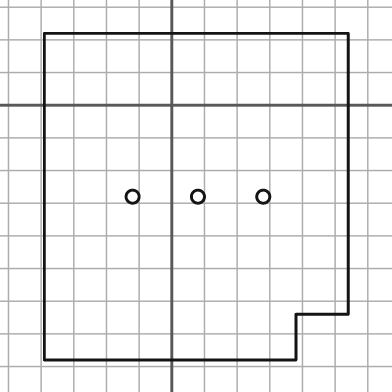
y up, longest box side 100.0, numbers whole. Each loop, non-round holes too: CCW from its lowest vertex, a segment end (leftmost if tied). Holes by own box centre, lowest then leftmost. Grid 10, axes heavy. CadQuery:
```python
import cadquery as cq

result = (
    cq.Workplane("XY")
    .moveTo(-39.0, -78.0)
    .lineTo(38.0, -78.0)
    .lineTo(38.0, -64.0)
    .lineTo(54.0, -64.0)
    .lineTo(54.0, 22.0)
    .lineTo(-39.0, 22.0)
    .close()
    .moveTo(-12.0, -28.0)
    .circle(2.0)
    .moveTo(8.0, -28.0)
    .circle(2.0)
    .moveTo(28.0, -28.0)
    .circle(2.0)
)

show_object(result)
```